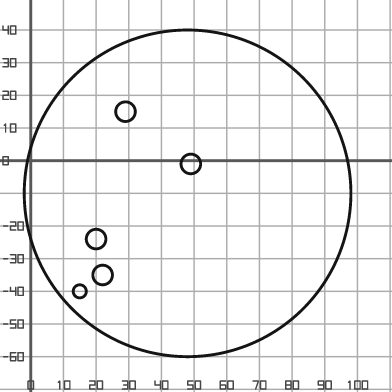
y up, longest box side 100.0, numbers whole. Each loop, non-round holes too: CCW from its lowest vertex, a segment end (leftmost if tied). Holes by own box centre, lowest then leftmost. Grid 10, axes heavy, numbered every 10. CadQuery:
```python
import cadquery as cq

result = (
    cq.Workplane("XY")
    .moveTo(48.0, -10.0)
    .circle(50.0)
    .moveTo(15.0, -40.0)
    .circle(2.0)
    .moveTo(22.0, -35.0)
    .circle(3.0)
    .moveTo(20.0, -24.0)
    .circle(3.0)
    .moveTo(49.0, -1.0)
    .circle(3.0)
    .moveTo(29.0, 15.0)
    .circle(3.0)
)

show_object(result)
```